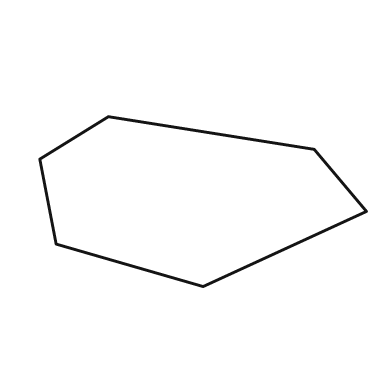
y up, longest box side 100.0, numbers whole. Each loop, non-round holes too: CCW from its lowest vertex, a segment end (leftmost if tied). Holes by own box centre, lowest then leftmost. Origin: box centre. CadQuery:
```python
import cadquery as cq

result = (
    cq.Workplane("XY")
    .moveTo(0.0, -26.0)
    .lineTo(50.0, -3.0)
    .lineTo(34.0, 16.0)
    .lineTo(-29.0, 26.0)
    .lineTo(-50.0, 13.0)
    .lineTo(-45.0, -13.0)
    .close()
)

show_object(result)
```